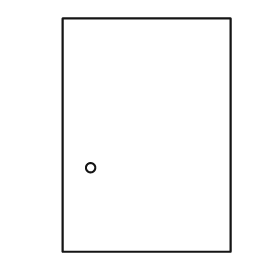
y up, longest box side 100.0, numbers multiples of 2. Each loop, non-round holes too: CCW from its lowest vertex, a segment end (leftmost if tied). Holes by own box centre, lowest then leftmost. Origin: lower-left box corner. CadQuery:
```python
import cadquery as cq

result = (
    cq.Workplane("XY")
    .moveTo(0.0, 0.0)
    .lineTo(72.0, 0.0)
    .lineTo(72.0, 100.0)
    .lineTo(0.0, 100.0)
    .close()
    .moveTo(12.0, 36.0)
    .circle(2.0)
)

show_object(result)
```